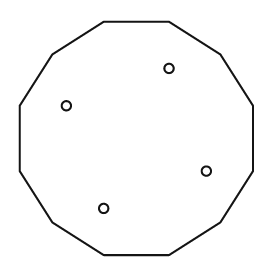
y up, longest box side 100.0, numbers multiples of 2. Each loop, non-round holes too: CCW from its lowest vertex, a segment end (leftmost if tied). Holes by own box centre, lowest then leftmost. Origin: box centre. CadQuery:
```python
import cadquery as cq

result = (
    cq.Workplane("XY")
    .moveTo(-14.0, -50.0)
    .lineTo(14.0, -50.0)
    .lineTo(36.0, -36.0)
    .lineTo(50.0, -14.0)
    .lineTo(50.0, 14.0)
    .lineTo(36.0, 36.0)
    .lineTo(14.0, 50.0)
    .lineTo(-14.0, 50.0)
    .lineTo(-36.0, 36.0)
    .lineTo(-50.0, 14.0)
    .lineTo(-50.0, -14.0)
    .lineTo(-36.0, -36.0)
    .close()
    .moveTo(-14.0, -30.0)
    .circle(2.0)
    .moveTo(30.0, -14.0)
    .circle(2.0)
    .moveTo(-30.0, 14.0)
    .circle(2.0)
    .moveTo(14.0, 30.0)
    .circle(2.0)
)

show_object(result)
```